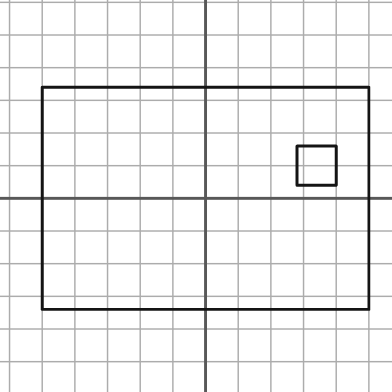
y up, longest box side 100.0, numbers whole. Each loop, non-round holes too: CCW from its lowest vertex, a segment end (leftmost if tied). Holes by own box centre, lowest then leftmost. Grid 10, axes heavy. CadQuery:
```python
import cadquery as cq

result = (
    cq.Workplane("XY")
    .moveTo(-50.0, -34.0)
    .lineTo(50.0, -34.0)
    .lineTo(50.0, 34.0)
    .lineTo(-50.0, 34.0)
    .close()
    .moveTo(28.0, 4.0)
    .lineTo(40.0, 4.0)
    .lineTo(40.0, 16.0)
    .lineTo(28.0, 16.0)
    .close()
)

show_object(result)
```